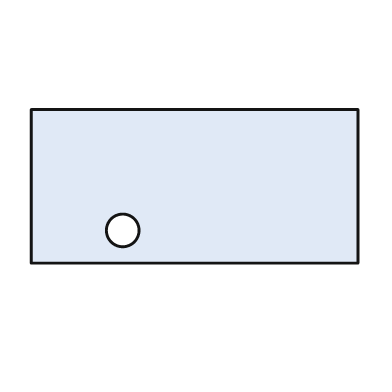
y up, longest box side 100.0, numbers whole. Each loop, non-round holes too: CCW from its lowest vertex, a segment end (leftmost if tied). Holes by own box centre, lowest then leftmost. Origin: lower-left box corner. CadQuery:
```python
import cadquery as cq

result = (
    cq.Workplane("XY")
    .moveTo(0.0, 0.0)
    .lineTo(100.0, 0.0)
    .lineTo(100.0, 47.0)
    .lineTo(0.0, 47.0)
    .close()
    .moveTo(28.0, 10.0)
    .circle(5.0)
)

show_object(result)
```